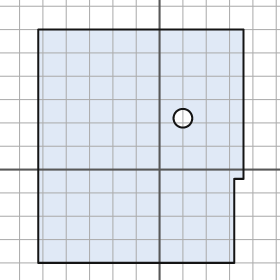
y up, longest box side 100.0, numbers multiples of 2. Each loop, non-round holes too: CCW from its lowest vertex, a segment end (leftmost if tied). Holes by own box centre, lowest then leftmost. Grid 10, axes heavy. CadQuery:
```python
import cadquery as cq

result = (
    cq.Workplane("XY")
    .moveTo(-52.0, -40.0)
    .lineTo(32.0, -40.0)
    .lineTo(32.0, -4.0)
    .lineTo(36.0, -4.0)
    .lineTo(36.0, 60.0)
    .lineTo(-52.0, 60.0)
    .close()
    .moveTo(10.0, 22.0)
    .circle(4.0)
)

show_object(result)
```